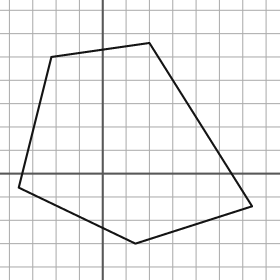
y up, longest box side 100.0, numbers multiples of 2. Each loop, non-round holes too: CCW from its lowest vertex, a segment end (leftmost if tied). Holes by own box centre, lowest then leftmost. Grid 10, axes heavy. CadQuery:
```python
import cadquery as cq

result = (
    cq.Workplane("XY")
    .moveTo(14.0, -30.0)
    .lineTo(64.0, -14.0)
    .lineTo(20.0, 56.0)
    .lineTo(-22.0, 50.0)
    .lineTo(-36.0, -6.0)
    .close()
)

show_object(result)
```